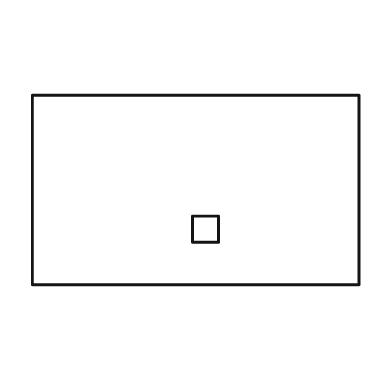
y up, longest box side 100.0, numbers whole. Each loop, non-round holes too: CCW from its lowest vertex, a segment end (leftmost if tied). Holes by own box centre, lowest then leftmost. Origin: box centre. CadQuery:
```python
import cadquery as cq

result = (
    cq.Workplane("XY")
    .moveTo(-50.0, -29.0)
    .lineTo(50.0, -29.0)
    .lineTo(50.0, 29.0)
    .lineTo(-50.0, 29.0)
    .close()
    .moveTo(-1.0, -16.0)
    .lineTo(7.0, -16.0)
    .lineTo(7.0, -8.0)
    .lineTo(-1.0, -8.0)
    .close()
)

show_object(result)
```